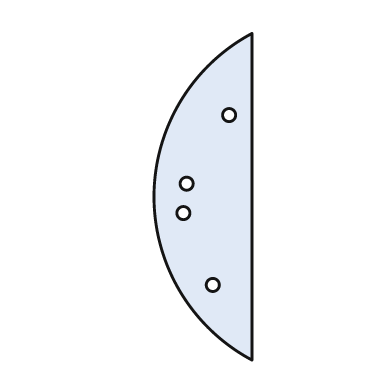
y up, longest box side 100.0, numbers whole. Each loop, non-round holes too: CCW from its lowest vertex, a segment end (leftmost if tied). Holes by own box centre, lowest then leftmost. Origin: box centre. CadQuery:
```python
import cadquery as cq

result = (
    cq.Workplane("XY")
    .moveTo(15.0, -50.0)
    .lineTo(15.0, 50.0)
    .threePointArc((-15.0, 0.0), (15.0, -50.0))
    .close()
    .moveTo(3.0, -27.0)
    .circle(2.0)
    .moveTo(-6.0, -5.0)
    .circle(2.0)
    .moveTo(-5.0, 4.0)
    .circle(2.0)
    .moveTo(8.0, 25.0)
    .circle(2.0)
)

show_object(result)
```